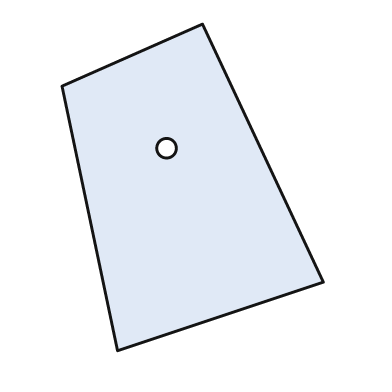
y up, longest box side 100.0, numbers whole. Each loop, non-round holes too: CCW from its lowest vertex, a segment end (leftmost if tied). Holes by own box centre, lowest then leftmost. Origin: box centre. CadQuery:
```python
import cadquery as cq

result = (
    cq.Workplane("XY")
    .moveTo(-23.0, -50.0)
    .lineTo(40.0, -29.0)
    .lineTo(3.0, 50.0)
    .lineTo(-40.0, 31.0)
    .close()
    .moveTo(-8.0, 12.0)
    .circle(3.0)
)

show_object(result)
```